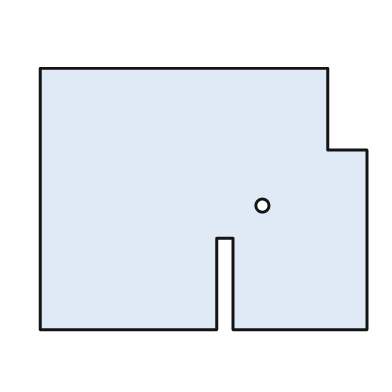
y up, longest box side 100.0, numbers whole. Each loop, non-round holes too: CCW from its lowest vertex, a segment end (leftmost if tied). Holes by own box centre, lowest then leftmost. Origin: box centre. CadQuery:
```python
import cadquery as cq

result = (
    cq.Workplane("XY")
    .moveTo(-50.0, -40.0)
    .lineTo(4.0, -40.0)
    .lineTo(4.0, -12.0)
    .lineTo(9.0, -12.0)
    .lineTo(9.0, -40.0)
    .lineTo(50.0, -40.0)
    .lineTo(50.0, 15.0)
    .lineTo(38.0, 15.0)
    .lineTo(38.0, 40.0)
    .lineTo(-50.0, 40.0)
    .close()
    .moveTo(18.0, -2.0)
    .circle(2.0)
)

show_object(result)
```